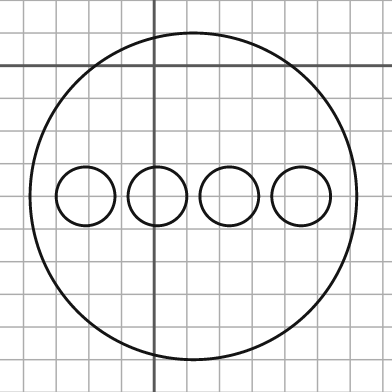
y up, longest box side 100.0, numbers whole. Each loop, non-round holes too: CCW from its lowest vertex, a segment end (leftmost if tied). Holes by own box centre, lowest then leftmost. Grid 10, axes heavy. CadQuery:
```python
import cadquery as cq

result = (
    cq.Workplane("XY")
    .moveTo(12.0, -40.0)
    .circle(50.0)
    .moveTo(-21.0, -40.0)
    .circle(9.0)
    .moveTo(1.0, -40.0)
    .circle(9.0)
    .moveTo(23.0, -40.0)
    .circle(9.0)
    .moveTo(45.0, -40.0)
    .circle(9.0)
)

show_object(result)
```